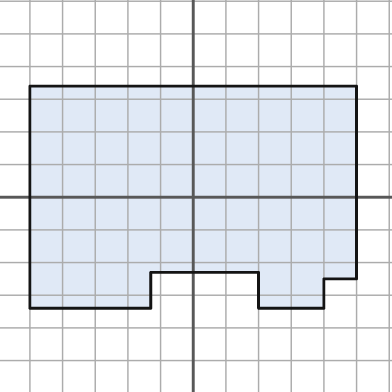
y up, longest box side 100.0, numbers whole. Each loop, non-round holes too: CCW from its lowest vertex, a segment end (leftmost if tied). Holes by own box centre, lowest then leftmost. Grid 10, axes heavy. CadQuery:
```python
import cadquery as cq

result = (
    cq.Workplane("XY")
    .moveTo(-50.0, -34.0)
    .lineTo(-13.0, -34.0)
    .lineTo(-13.0, -23.0)
    .lineTo(20.0, -23.0)
    .lineTo(20.0, -34.0)
    .lineTo(40.0, -34.0)
    .lineTo(40.0, -25.0)
    .lineTo(50.0, -25.0)
    .lineTo(50.0, 34.0)
    .lineTo(-50.0, 34.0)
    .close()
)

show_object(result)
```